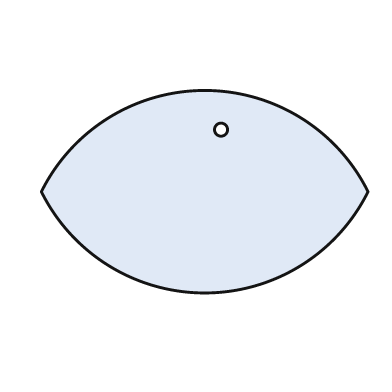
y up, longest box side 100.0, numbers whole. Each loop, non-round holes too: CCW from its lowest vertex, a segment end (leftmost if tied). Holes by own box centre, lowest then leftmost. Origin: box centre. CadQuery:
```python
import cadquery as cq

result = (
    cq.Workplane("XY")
    .moveTo(-50.0, 0.0)
    .threePointArc((0.0, -31.0), (50.0, 0.0))
    .threePointArc((0.0, 31.0), (-50.0, 0.0))
    .close()
    .moveTo(5.0, 19.0)
    .circle(2.0)
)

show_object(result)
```